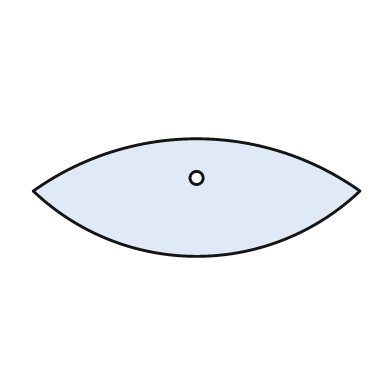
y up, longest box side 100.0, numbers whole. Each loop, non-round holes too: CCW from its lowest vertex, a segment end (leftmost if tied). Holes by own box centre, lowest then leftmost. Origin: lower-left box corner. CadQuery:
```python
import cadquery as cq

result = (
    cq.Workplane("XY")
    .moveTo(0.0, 20.0)
    .threePointArc((50.0, 0.0), (100.0, 20.0))
    .threePointArc((50.0, 36.0), (0.0, 20.0))
    .close()
    .moveTo(50.0, 24.0)
    .circle(2.0)
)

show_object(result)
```